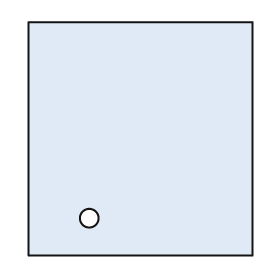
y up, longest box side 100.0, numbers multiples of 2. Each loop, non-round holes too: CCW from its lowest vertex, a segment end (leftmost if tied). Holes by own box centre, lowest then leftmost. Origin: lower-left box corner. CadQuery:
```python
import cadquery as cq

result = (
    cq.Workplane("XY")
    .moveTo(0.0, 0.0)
    .lineTo(96.0, 0.0)
    .lineTo(96.0, 100.0)
    .lineTo(0.0, 100.0)
    .close()
    .moveTo(26.0, 16.0)
    .circle(4.0)
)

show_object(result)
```